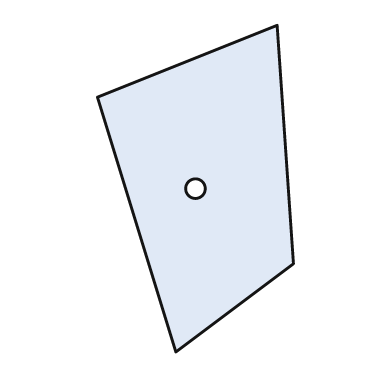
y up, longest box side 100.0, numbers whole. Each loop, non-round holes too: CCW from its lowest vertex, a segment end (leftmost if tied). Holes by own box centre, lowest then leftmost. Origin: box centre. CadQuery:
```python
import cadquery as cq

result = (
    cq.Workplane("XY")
    .moveTo(-6.0, -50.0)
    .lineTo(30.0, -23.0)
    .lineTo(25.0, 50.0)
    .lineTo(-30.0, 28.0)
    .close()
    .moveTo(0.0, 0.0)
    .circle(3.0)
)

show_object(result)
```